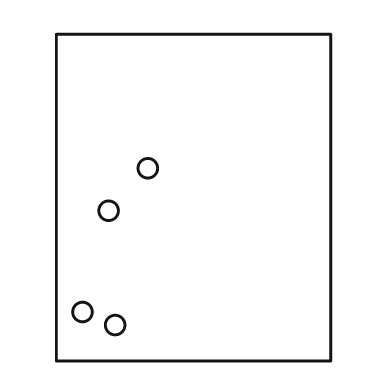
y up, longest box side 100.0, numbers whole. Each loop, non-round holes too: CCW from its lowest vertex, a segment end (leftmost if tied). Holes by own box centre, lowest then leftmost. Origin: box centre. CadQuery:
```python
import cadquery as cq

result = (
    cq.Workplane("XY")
    .moveTo(-42.0, -50.0)
    .lineTo(42.0, -50.0)
    .lineTo(42.0, 50.0)
    .lineTo(-42.0, 50.0)
    .close()
    .moveTo(-24.0, -39.0)
    .circle(3.0)
    .moveTo(-34.0, -35.0)
    .circle(3.0)
    .moveTo(-26.0, -4.0)
    .circle(3.0)
    .moveTo(-14.0, 9.0)
    .circle(3.0)
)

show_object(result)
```